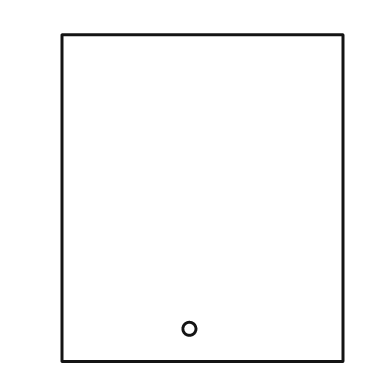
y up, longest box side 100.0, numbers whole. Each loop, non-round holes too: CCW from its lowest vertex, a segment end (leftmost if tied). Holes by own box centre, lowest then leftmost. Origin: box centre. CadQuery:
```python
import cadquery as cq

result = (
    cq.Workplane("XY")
    .moveTo(-43.0, -50.0)
    .lineTo(43.0, -50.0)
    .lineTo(43.0, 50.0)
    .lineTo(-43.0, 50.0)
    .close()
    .moveTo(-4.0, -40.0)
    .circle(2.0)
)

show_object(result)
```